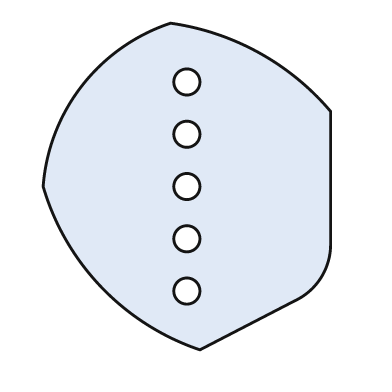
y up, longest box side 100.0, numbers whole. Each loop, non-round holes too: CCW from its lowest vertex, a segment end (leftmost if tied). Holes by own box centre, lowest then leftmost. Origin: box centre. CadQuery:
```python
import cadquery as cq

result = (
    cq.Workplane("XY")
    .moveTo(4.0, -50.0)
    .lineTo(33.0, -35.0)
    .threePointArc((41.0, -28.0), (44.0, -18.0))
    .lineTo(44.0, 23.0)
    .threePointArc((22.0, 41.0), (-5.0, 50.0))
    .threePointArc((-32.0, 31.0), (-44.0, 0.0))
    .threePointArc((-26.0, -31.0), (4.0, -50.0))
    .close()
    .moveTo(0.0, -32.0)
    .circle(4.0)
    .moveTo(0.0, -16.0)
    .circle(4.0)
    .moveTo(0.0, 0.0)
    .circle(4.0)
    .moveTo(0.0, 16.0)
    .circle(4.0)
    .moveTo(0.0, 32.0)
    .circle(4.0)
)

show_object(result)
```